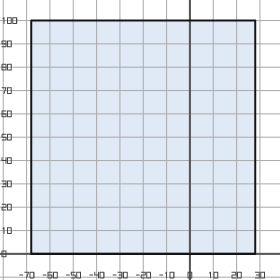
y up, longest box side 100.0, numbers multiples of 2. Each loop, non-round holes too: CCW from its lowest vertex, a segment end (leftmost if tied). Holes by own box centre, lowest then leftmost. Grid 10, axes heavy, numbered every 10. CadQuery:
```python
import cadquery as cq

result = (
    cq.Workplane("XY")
    .moveTo(-68.0, 0.0)
    .lineTo(28.0, 0.0)
    .lineTo(28.0, 100.0)
    .lineTo(-68.0, 100.0)
    .close()
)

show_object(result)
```